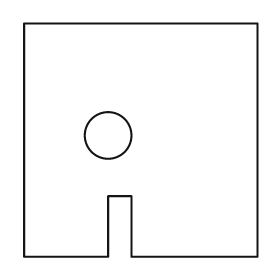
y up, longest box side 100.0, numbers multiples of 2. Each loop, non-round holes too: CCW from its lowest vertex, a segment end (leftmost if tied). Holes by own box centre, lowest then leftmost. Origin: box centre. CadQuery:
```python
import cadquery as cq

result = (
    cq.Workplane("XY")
    .moveTo(-50.0, -50.0)
    .lineTo(-14.0, -50.0)
    .lineTo(-14.0, -24.0)
    .lineTo(-4.0, -24.0)
    .lineTo(-4.0, -50.0)
    .lineTo(50.0, -50.0)
    .lineTo(50.0, 50.0)
    .lineTo(-50.0, 50.0)
    .close()
    .moveTo(-14.0, 2.0)
    .circle(10.0)
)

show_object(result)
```